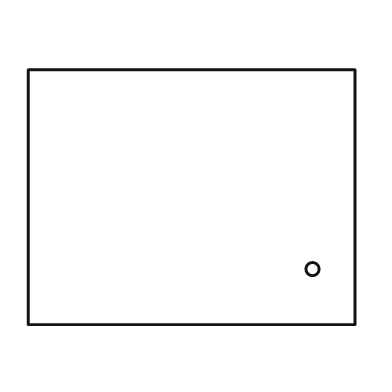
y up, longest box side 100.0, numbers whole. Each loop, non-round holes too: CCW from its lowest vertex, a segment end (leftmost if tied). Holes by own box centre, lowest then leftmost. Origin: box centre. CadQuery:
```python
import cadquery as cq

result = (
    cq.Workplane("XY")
    .moveTo(-50.0, -39.0)
    .lineTo(50.0, -39.0)
    .lineTo(50.0, 39.0)
    .lineTo(-50.0, 39.0)
    .close()
    .moveTo(37.0, -22.0)
    .circle(2.0)
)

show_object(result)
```